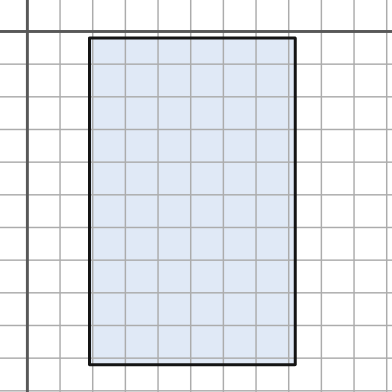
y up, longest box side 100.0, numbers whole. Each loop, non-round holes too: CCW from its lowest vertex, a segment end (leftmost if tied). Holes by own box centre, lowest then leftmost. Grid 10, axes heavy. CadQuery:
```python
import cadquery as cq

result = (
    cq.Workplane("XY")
    .moveTo(19.0, -102.0)
    .lineTo(82.0, -102.0)
    .lineTo(82.0, -2.0)
    .lineTo(19.0, -2.0)
    .close()
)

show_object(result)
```